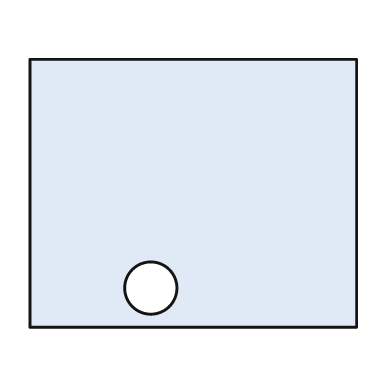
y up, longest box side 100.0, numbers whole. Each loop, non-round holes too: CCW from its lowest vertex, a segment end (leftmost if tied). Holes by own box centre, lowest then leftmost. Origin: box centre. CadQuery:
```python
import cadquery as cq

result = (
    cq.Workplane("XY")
    .moveTo(-50.0, -41.0)
    .lineTo(50.0, -41.0)
    .lineTo(50.0, 41.0)
    .lineTo(-50.0, 41.0)
    .close()
    .moveTo(-13.0, -29.0)
    .circle(8.0)
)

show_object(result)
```